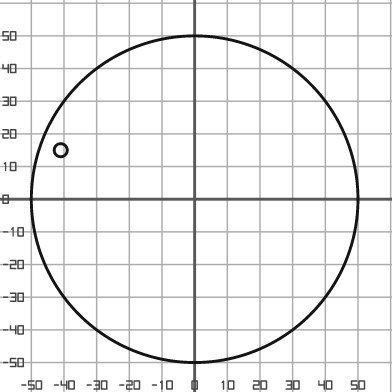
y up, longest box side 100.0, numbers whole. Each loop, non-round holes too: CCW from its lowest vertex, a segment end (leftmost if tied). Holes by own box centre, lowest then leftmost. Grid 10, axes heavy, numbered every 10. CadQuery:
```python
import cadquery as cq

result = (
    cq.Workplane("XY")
    .moveTo(0.0, 0.0)
    .circle(50.0)
    .moveTo(-41.0, 15.0)
    .circle(2.0)
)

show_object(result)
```